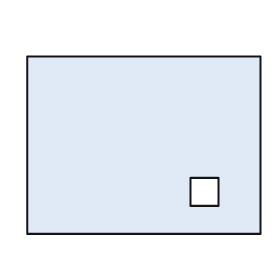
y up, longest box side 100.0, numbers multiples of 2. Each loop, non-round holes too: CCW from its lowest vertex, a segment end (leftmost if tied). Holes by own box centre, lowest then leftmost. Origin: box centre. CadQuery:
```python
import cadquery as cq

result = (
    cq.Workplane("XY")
    .moveTo(-50.0, -38.0)
    .lineTo(50.0, -38.0)
    .lineTo(50.0, 38.0)
    .lineTo(-50.0, 38.0)
    .close()
    .moveTo(20.0, -26.0)
    .lineTo(32.0, -26.0)
    .lineTo(32.0, -14.0)
    .lineTo(20.0, -14.0)
    .close()
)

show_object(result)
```